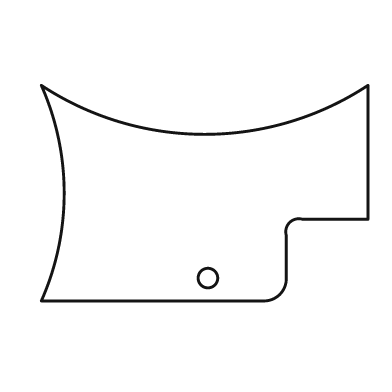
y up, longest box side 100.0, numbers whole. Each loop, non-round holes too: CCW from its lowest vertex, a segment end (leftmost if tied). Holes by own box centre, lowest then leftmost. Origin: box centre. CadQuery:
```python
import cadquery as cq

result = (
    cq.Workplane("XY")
    .moveTo(-50.0, -33.0)
    .lineTo(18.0, -33.0)
    .threePointArc((23.0, -31.0), (25.0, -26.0))
    .lineTo(25.0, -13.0)
    .threePointArc((26.0, -9.0), (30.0, -8.0))
    .lineTo(50.0, -8.0)
    .lineTo(50.0, 33.0)
    .threePointArc((0.0, 18.0), (-50.0, 33.0))
    .threePointArc((-43.0, 0.0), (-50.0, -33.0))
    .close()
    .moveTo(1.0, -26.0)
    .circle(3.0)
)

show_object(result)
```